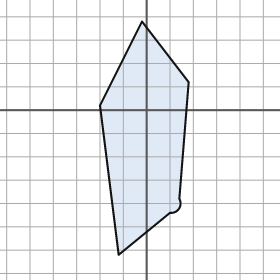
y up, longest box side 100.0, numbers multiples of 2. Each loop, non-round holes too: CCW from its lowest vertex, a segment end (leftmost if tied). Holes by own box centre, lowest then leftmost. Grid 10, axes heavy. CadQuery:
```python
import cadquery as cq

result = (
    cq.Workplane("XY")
    .moveTo(-12.0, -62.0)
    .lineTo(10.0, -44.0)
    .threePointArc((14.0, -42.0), (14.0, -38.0))
    .lineTo(18.0, 12.0)
    .lineTo(-2.0, 38.0)
    .lineTo(-20.0, 2.0)
    .close()
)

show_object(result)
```